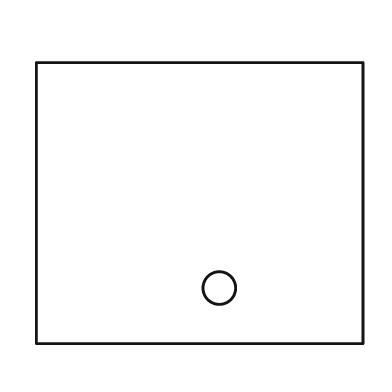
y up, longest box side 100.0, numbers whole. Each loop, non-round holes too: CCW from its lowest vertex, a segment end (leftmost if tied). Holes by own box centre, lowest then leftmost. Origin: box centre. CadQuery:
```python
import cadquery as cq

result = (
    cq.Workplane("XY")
    .moveTo(-50.0, -43.0)
    .lineTo(50.0, -43.0)
    .lineTo(50.0, 43.0)
    .lineTo(-50.0, 43.0)
    .close()
    .moveTo(6.0, -26.0)
    .circle(5.0)
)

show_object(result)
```